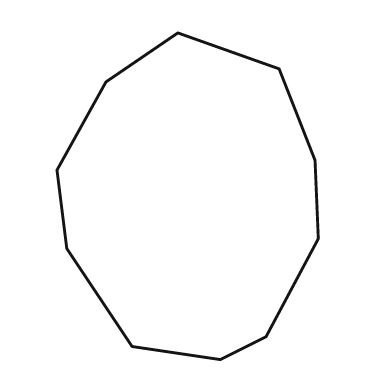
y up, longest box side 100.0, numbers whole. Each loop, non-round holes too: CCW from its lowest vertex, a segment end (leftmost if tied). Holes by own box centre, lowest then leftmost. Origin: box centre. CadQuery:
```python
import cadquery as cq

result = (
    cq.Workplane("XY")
    .moveTo(10.0, -50.0)
    .lineTo(24.0, -43.0)
    .lineTo(40.0, -13.0)
    .lineTo(39.0, 11.0)
    .lineTo(28.0, 39.0)
    .lineTo(-3.0, 50.0)
    .lineTo(-25.0, 35.0)
    .lineTo(-40.0, 8.0)
    .lineTo(-37.0, -16.0)
    .lineTo(-17.0, -46.0)
    .close()
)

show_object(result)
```